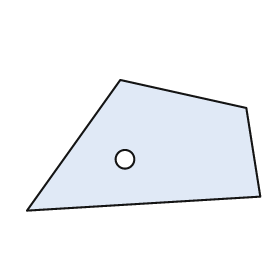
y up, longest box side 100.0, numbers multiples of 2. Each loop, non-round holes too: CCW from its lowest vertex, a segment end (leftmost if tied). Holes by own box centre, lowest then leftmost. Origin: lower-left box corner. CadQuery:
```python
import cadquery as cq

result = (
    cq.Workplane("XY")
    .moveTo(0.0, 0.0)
    .lineTo(100.0, 6.0)
    .lineTo(94.0, 44.0)
    .lineTo(40.0, 56.0)
    .close()
    .moveTo(42.0, 22.0)
    .circle(4.0)
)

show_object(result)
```